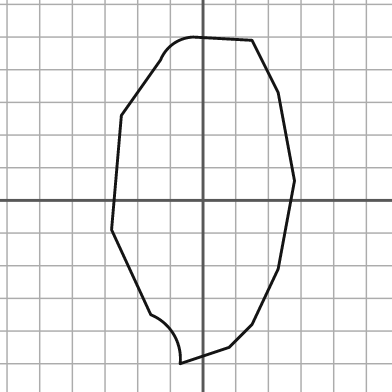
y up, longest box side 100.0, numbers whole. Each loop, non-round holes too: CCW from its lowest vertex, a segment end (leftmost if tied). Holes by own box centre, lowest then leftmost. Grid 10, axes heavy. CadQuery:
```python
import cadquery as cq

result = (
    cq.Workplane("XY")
    .moveTo(-7.0, -50.0)
    .lineTo(8.0, -45.0)
    .lineTo(15.0, -38.0)
    .lineTo(23.0, -21.0)
    .lineTo(28.0, 6.0)
    .lineTo(23.0, 33.0)
    .lineTo(15.0, 49.0)
    .lineTo(-3.0, 50.0)
    .threePointArc((-9.0, 48.0), (-13.0, 43.0))
    .lineTo(-25.0, 26.0)
    .lineTo(-28.0, -9.0)
    .lineTo(-16.0, -35.0)
    .threePointArc((-9.0, -41.0), (-7.0, -50.0))
    .close()
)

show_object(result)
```